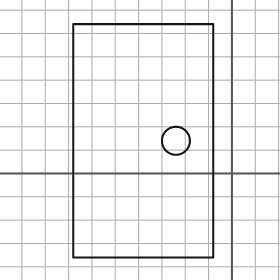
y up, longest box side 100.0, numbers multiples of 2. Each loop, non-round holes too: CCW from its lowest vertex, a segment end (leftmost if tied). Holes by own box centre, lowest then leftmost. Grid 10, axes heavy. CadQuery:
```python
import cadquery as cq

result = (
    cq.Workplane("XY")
    .moveTo(-68.0, -36.0)
    .lineTo(-8.0, -36.0)
    .lineTo(-8.0, 64.0)
    .lineTo(-68.0, 64.0)
    .close()
    .moveTo(-24.0, 14.0)
    .circle(6.0)
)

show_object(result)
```